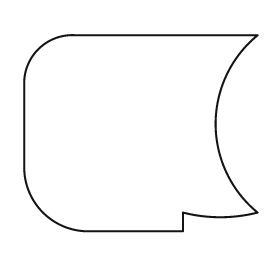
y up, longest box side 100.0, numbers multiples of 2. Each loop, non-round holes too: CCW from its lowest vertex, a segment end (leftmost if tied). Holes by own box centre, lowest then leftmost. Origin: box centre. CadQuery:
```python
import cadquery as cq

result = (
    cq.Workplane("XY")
    .moveTo(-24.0, -42.0)
    .lineTo(18.0, -42.0)
    .lineTo(18.0, -34.0)
    .threePointArc((34.0, -36.0), (50.0, -34.0))
    .threePointArc((32.0, 4.0), (50.0, 42.0))
    .lineTo(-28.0, 42.0)
    .threePointArc((-44.0, 36.0), (-50.0, 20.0))
    .lineTo(-50.0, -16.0)
    .threePointArc((-42.0, -34.0), (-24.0, -42.0))
    .close()
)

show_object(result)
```